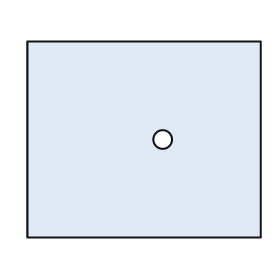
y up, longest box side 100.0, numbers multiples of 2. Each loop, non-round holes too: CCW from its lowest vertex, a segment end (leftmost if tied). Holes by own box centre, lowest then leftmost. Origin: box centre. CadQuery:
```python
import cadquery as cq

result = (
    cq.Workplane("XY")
    .moveTo(-50.0, -42.0)
    .lineTo(50.0, -42.0)
    .lineTo(50.0, 42.0)
    .lineTo(-50.0, 42.0)
    .close()
    .moveTo(8.0, 0.0)
    .circle(4.0)
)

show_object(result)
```